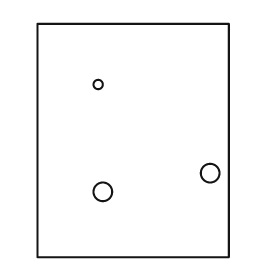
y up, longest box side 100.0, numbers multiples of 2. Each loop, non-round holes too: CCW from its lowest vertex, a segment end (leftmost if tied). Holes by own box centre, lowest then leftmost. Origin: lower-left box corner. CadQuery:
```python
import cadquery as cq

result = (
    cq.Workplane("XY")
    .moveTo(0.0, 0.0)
    .lineTo(82.0, 0.0)
    .lineTo(82.0, 100.0)
    .lineTo(0.0, 100.0)
    .close()
    .moveTo(28.0, 28.0)
    .circle(4.0)
    .moveTo(74.0, 36.0)
    .circle(4.0)
    .moveTo(26.0, 74.0)
    .circle(2.0)
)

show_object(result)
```